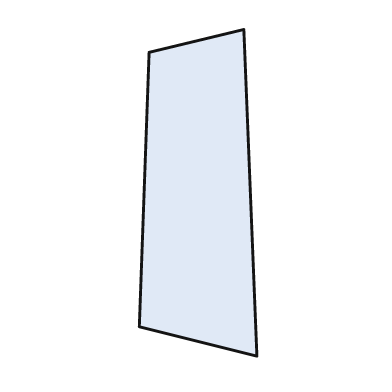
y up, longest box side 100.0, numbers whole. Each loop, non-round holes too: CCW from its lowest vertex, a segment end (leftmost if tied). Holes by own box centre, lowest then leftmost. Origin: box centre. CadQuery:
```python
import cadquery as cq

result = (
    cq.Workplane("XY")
    .moveTo(18.0, -50.0)
    .lineTo(14.0, 50.0)
    .lineTo(-15.0, 43.0)
    .lineTo(-18.0, -41.0)
    .close()
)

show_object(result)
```